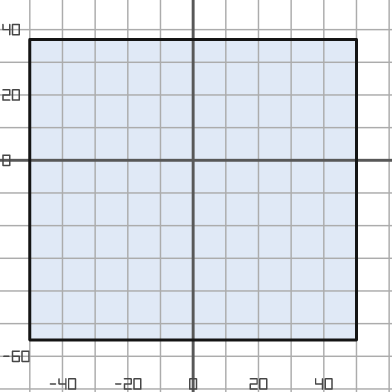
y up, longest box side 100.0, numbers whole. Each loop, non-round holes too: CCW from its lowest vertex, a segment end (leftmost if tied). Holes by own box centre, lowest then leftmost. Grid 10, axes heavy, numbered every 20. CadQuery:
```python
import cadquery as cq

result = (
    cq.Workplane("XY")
    .moveTo(-50.0, -55.0)
    .lineTo(50.0, -55.0)
    .lineTo(50.0, 37.0)
    .lineTo(-50.0, 37.0)
    .close()
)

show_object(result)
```